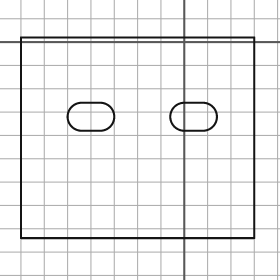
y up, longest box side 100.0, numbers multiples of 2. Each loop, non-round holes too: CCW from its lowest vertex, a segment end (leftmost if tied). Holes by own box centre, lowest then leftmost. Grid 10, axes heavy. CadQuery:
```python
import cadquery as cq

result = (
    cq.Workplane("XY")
    .moveTo(-70.0, -84.0)
    .lineTo(30.0, -84.0)
    .lineTo(30.0, 2.0)
    .lineTo(-70.0, 2.0)
    .close()
    .moveTo(-44.0, -38.0)
    .lineTo(-36.0, -38.0)
    .threePointArc((-30.0, -32.0), (-36.0, -26.0))
    .lineTo(-44.0, -26.0)
    .threePointArc((-50.0, -32.0), (-44.0, -38.0))
    .close()
    .moveTo(0.0, -38.0)
    .lineTo(8.0, -38.0)
    .threePointArc((14.0, -32.0), (8.0, -26.0))
    .lineTo(0.0, -26.0)
    .threePointArc((-6.0, -32.0), (0.0, -38.0))
    .close()
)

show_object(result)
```